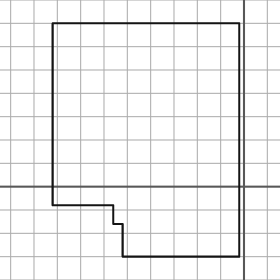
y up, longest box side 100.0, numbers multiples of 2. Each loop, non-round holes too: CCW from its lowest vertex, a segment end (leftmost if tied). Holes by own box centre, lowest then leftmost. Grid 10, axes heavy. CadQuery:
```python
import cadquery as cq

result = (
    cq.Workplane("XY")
    .moveTo(-52.0, -30.0)
    .lineTo(-2.0, -30.0)
    .lineTo(-2.0, 70.0)
    .lineTo(-82.0, 70.0)
    .lineTo(-82.0, -8.0)
    .lineTo(-56.0, -8.0)
    .lineTo(-56.0, -16.0)
    .lineTo(-52.0, -16.0)
    .close()
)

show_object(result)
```